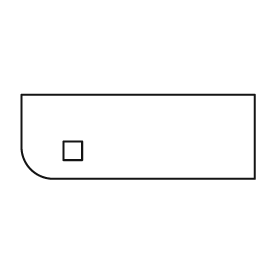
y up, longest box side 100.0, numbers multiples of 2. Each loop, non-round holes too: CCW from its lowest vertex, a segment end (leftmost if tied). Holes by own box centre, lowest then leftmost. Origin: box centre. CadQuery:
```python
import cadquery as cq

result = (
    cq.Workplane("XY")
    .moveTo(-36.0, -18.0)
    .lineTo(50.0, -18.0)
    .lineTo(50.0, 18.0)
    .lineTo(-50.0, 18.0)
    .lineTo(-50.0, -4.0)
    .threePointArc((-46.0, -14.0), (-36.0, -18.0))
    .close()
    .moveTo(-32.0, -10.0)
    .lineTo(-24.0, -10.0)
    .lineTo(-24.0, -2.0)
    .lineTo(-32.0, -2.0)
    .close()
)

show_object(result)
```